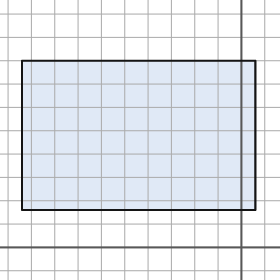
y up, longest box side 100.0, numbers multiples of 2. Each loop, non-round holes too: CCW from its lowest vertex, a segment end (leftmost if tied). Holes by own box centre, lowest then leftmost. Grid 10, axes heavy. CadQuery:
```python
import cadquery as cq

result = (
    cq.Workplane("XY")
    .moveTo(-94.0, 16.0)
    .lineTo(6.0, 16.0)
    .lineTo(6.0, 80.0)
    .lineTo(-94.0, 80.0)
    .close()
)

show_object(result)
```